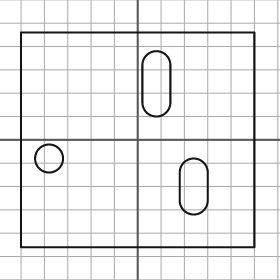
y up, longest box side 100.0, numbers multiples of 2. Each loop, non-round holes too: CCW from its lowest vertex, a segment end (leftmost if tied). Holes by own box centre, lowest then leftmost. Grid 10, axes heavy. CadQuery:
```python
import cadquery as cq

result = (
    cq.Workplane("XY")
    .moveTo(-50.0, -46.0)
    .lineTo(50.0, -46.0)
    .lineTo(50.0, 46.0)
    .lineTo(-50.0, 46.0)
    .close()
    .moveTo(18.0, -26.0)
    .threePointArc((24.0, -32.0), (30.0, -26.0))
    .lineTo(30.0, -14.0)
    .threePointArc((24.0, -8.0), (18.0, -14.0))
    .close()
    .moveTo(-38.0, -8.0)
    .circle(6.0)
    .moveTo(2.0, 16.0)
    .threePointArc((8.0, 10.0), (14.0, 16.0))
    .lineTo(14.0, 32.0)
    .threePointArc((8.0, 38.0), (2.0, 32.0))
    .close()
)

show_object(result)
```